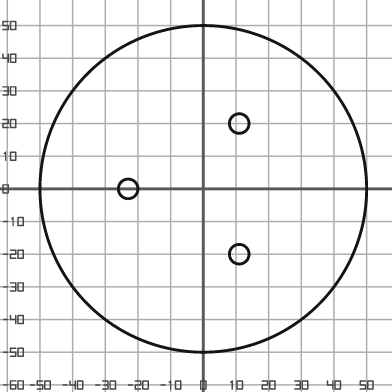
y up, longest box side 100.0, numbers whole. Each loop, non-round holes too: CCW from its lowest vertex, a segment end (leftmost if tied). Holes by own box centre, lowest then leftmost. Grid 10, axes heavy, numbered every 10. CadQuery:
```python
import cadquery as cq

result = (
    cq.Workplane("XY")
    .moveTo(0.0, 0.0)
    .circle(50.0)
    .moveTo(11.0, -20.0)
    .circle(3.0)
    .moveTo(-23.0, 0.0)
    .circle(3.0)
    .moveTo(11.0, 20.0)
    .circle(3.0)
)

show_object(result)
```